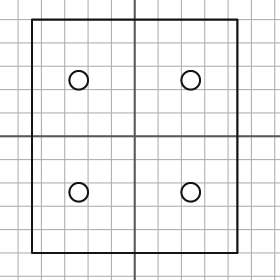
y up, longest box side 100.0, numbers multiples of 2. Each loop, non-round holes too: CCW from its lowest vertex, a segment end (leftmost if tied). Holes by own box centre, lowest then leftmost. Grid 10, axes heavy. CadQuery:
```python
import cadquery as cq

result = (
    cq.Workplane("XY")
    .moveTo(-44.0, -50.0)
    .lineTo(44.0, -50.0)
    .lineTo(44.0, 50.0)
    .lineTo(-44.0, 50.0)
    .close()
    .moveTo(-24.0, -24.0)
    .circle(4.0)
    .moveTo(24.0, -24.0)
    .circle(4.0)
    .moveTo(-24.0, 24.0)
    .circle(4.0)
    .moveTo(24.0, 24.0)
    .circle(4.0)
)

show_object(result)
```